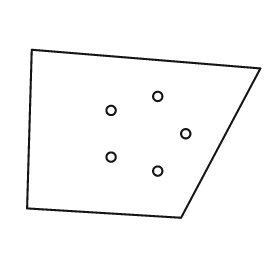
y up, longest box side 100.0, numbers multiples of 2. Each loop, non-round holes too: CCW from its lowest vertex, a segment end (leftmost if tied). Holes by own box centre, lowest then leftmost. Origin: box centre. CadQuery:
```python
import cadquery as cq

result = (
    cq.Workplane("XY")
    .moveTo(16.0, -36.0)
    .lineTo(50.0, 28.0)
    .lineTo(-48.0, 36.0)
    .lineTo(-50.0, -32.0)
    .close()
    .moveTo(6.0, -16.0)
    .circle(2.0)
    .moveTo(-14.0, -10.0)
    .circle(2.0)
    .moveTo(18.0, 0.0)
    .circle(2.0)
    .moveTo(-14.0, 10.0)
    .circle(2.0)
    .moveTo(6.0, 16.0)
    .circle(2.0)
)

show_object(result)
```